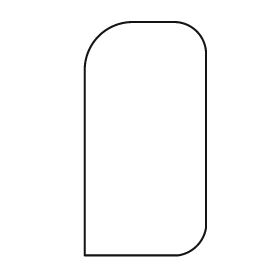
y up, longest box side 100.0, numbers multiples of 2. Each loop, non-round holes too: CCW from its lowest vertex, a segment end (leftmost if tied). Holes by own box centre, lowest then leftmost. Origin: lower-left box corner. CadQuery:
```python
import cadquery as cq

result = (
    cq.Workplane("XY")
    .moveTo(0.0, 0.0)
    .lineTo(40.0, 0.0)
    .threePointArc((48.0, 4.0), (52.0, 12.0))
    .lineTo(52.0, 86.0)
    .threePointArc((48.0, 96.0), (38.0, 100.0))
    .lineTo(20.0, 100.0)
    .threePointArc((6.0, 94.0), (0.0, 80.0))
    .close()
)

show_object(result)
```